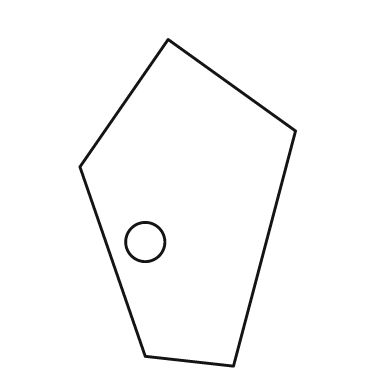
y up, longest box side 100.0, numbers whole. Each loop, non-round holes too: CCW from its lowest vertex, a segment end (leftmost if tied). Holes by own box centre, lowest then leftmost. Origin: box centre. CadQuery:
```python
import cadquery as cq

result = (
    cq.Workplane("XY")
    .moveTo(14.0, -50.0)
    .lineTo(33.0, 22.0)
    .lineTo(-6.0, 50.0)
    .lineTo(-33.0, 11.0)
    .lineTo(-13.0, -47.0)
    .close()
    .moveTo(-13.0, -12.0)
    .circle(6.0)
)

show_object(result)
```